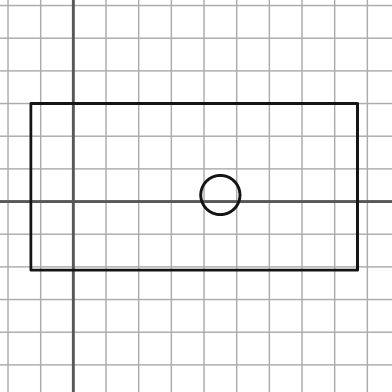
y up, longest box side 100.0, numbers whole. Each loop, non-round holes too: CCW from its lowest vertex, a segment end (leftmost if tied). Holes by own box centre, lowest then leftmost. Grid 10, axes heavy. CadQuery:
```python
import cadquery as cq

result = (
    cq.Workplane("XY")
    .moveTo(-13.0, -21.0)
    .lineTo(87.0, -21.0)
    .lineTo(87.0, 30.0)
    .lineTo(-13.0, 30.0)
    .close()
    .moveTo(45.0, 2.0)
    .circle(6.0)
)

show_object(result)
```